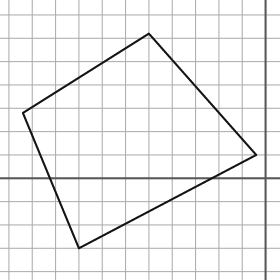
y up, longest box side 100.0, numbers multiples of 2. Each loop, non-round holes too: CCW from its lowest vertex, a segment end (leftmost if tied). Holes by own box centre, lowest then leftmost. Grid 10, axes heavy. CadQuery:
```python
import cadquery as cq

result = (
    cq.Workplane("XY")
    .moveTo(-80.0, -30.0)
    .lineTo(-4.0, 10.0)
    .lineTo(-50.0, 62.0)
    .lineTo(-104.0, 28.0)
    .close()
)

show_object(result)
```